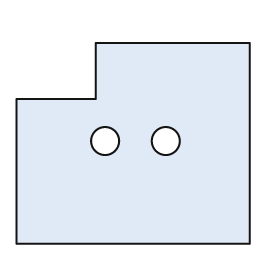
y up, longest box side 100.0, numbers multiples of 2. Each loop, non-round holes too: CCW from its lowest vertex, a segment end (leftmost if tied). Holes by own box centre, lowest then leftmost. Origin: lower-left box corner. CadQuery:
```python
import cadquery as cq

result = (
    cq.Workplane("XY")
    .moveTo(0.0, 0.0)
    .lineTo(100.0, 0.0)
    .lineTo(100.0, 86.0)
    .lineTo(34.0, 86.0)
    .lineTo(34.0, 62.0)
    .lineTo(0.0, 62.0)
    .close()
    .moveTo(38.0, 44.0)
    .circle(6.0)
    .moveTo(64.0, 44.0)
    .circle(6.0)
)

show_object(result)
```